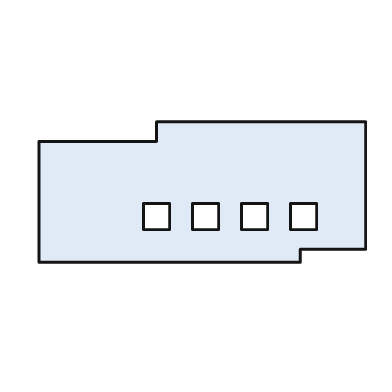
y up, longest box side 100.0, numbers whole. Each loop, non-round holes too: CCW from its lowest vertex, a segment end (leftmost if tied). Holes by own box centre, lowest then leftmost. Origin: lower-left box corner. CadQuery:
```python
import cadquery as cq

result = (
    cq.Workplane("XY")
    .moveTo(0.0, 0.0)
    .lineTo(80.0, 0.0)
    .lineTo(80.0, 4.0)
    .lineTo(100.0, 4.0)
    .lineTo(100.0, 43.0)
    .lineTo(36.0, 43.0)
    .lineTo(36.0, 37.0)
    .lineTo(0.0, 37.0)
    .close()
    .moveTo(32.0, 10.0)
    .lineTo(40.0, 10.0)
    .lineTo(40.0, 18.0)
    .lineTo(32.0, 18.0)
    .close()
    .moveTo(47.0, 10.0)
    .lineTo(55.0, 10.0)
    .lineTo(55.0, 18.0)
    .lineTo(47.0, 18.0)
    .close()
    .moveTo(62.0, 10.0)
    .lineTo(70.0, 10.0)
    .lineTo(70.0, 18.0)
    .lineTo(62.0, 18.0)
    .close()
    .moveTo(77.0, 10.0)
    .lineTo(85.0, 10.0)
    .lineTo(85.0, 18.0)
    .lineTo(77.0, 18.0)
    .close()
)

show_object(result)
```